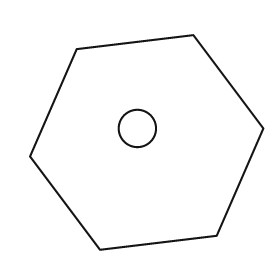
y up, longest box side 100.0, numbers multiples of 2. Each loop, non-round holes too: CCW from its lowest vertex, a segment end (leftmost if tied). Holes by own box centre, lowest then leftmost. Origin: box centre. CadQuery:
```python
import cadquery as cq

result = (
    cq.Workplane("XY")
    .moveTo(-20.0, -46.0)
    .lineTo(30.0, -40.0)
    .lineTo(50.0, 6.0)
    .lineTo(20.0, 46.0)
    .lineTo(-30.0, 40.0)
    .lineTo(-50.0, -6.0)
    .close()
    .moveTo(-4.0, 6.0)
    .circle(8.0)
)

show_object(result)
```